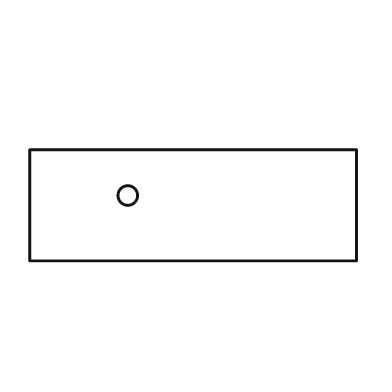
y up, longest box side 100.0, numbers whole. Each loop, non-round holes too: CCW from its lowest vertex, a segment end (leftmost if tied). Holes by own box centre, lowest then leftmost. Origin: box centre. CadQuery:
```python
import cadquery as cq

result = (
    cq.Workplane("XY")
    .moveTo(-50.0, -17.0)
    .lineTo(50.0, -17.0)
    .lineTo(50.0, 17.0)
    .lineTo(-50.0, 17.0)
    .close()
    .moveTo(-20.0, 3.0)
    .circle(3.0)
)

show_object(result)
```